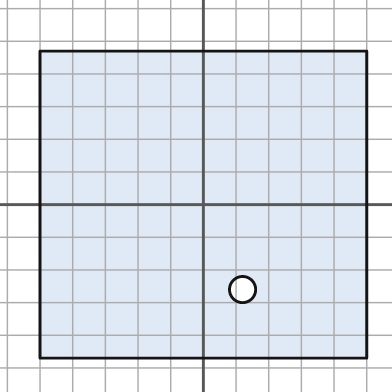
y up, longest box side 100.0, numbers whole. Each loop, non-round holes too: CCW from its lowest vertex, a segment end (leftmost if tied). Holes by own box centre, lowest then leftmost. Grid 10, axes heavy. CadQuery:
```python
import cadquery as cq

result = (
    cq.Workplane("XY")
    .moveTo(-50.0, -47.0)
    .lineTo(50.0, -47.0)
    .lineTo(50.0, 47.0)
    .lineTo(-50.0, 47.0)
    .close()
    .moveTo(12.0, -26.0)
    .circle(4.0)
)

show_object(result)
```